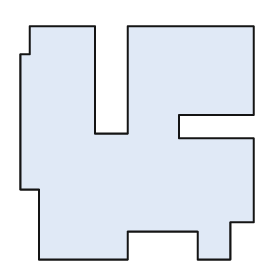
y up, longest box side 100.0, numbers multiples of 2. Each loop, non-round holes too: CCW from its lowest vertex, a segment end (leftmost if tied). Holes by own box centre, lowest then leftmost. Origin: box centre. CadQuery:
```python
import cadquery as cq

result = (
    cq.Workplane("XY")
    .moveTo(-42.0, -50.0)
    .lineTo(-4.0, -50.0)
    .lineTo(-4.0, -38.0)
    .lineTo(26.0, -38.0)
    .lineTo(26.0, -50.0)
    .lineTo(40.0, -50.0)
    .lineTo(40.0, -34.0)
    .lineTo(50.0, -34.0)
    .lineTo(50.0, 2.0)
    .lineTo(18.0, 2.0)
    .lineTo(18.0, 12.0)
    .lineTo(50.0, 12.0)
    .lineTo(50.0, 50.0)
    .lineTo(-4.0, 50.0)
    .lineTo(-4.0, 4.0)
    .lineTo(-18.0, 4.0)
    .lineTo(-18.0, 50.0)
    .lineTo(-46.0, 50.0)
    .lineTo(-46.0, 38.0)
    .lineTo(-50.0, 38.0)
    .lineTo(-50.0, -20.0)
    .lineTo(-42.0, -20.0)
    .close()
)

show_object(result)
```